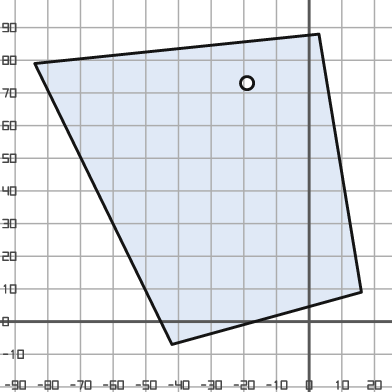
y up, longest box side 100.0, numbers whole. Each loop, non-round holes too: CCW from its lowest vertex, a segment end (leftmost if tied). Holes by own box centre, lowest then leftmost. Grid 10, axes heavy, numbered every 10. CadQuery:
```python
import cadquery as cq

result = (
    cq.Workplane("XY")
    .moveTo(-42.0, -7.0)
    .lineTo(16.0, 9.0)
    .lineTo(3.0, 88.0)
    .lineTo(-84.0, 79.0)
    .close()
    .moveTo(-19.0, 73.0)
    .circle(2.0)
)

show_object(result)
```